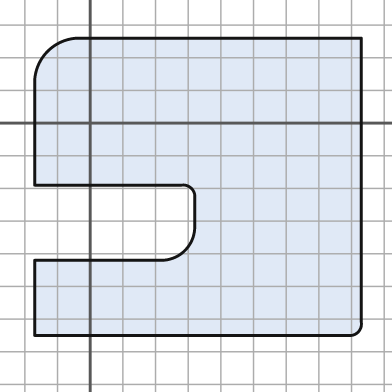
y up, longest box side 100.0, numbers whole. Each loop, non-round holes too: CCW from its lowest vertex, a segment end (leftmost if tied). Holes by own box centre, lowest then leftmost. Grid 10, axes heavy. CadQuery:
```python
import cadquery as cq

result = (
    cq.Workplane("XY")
    .moveTo(-17.0, -65.0)
    .lineTo(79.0, -65.0)
    .threePointArc((82.0, -64.0), (83.0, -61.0))
    .lineTo(83.0, 26.0)
    .lineTo(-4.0, 26.0)
    .threePointArc((-13.0, 22.0), (-17.0, 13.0))
    .lineTo(-17.0, -19.0)
    .lineTo(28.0, -19.0)
    .threePointArc((31.0, -20.0), (32.0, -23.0))
    .lineTo(32.0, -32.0)
    .threePointArc((29.0, -39.0), (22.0, -42.0))
    .lineTo(-17.0, -42.0)
    .close()
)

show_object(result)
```